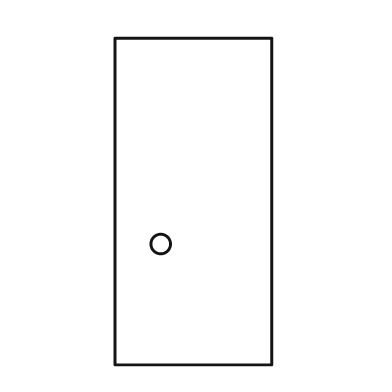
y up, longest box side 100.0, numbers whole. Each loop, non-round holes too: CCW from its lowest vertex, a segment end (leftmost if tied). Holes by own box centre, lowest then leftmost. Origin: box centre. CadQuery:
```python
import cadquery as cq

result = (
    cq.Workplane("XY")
    .moveTo(-24.0, -50.0)
    .lineTo(24.0, -50.0)
    .lineTo(24.0, 50.0)
    .lineTo(-24.0, 50.0)
    .close()
    .moveTo(-10.0, -13.0)
    .circle(3.0)
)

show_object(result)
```